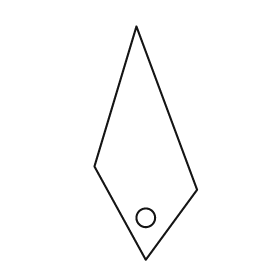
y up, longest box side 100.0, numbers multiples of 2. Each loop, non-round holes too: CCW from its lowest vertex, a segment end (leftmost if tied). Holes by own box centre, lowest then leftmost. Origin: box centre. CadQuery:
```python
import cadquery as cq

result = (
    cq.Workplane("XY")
    .moveTo(0.0, -50.0)
    .lineTo(22.0, -20.0)
    .lineTo(-4.0, 50.0)
    .lineTo(-22.0, -10.0)
    .close()
    .moveTo(0.0, -32.0)
    .circle(4.0)
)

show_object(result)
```